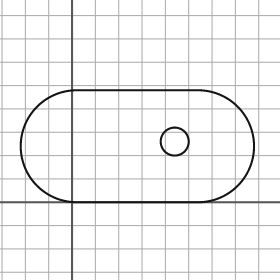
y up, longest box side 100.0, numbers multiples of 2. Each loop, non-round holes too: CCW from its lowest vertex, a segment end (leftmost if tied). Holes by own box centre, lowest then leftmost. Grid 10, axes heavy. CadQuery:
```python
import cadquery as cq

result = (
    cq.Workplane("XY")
    .moveTo(2.0, 0.0)
    .lineTo(54.0, 0.0)
    .threePointArc((78.0, 24.0), (54.0, 48.0))
    .lineTo(2.0, 48.0)
    .threePointArc((-22.0, 24.0), (2.0, 0.0))
    .close()
    .moveTo(44.0, 26.0)
    .circle(6.0)
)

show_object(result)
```